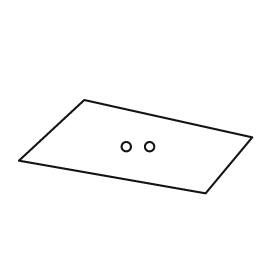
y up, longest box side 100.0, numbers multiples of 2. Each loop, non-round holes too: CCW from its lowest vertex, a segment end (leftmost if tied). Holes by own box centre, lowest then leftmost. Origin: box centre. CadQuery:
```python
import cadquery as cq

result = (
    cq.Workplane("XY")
    .moveTo(30.0, -20.0)
    .lineTo(50.0, 4.0)
    .lineTo(-22.0, 20.0)
    .lineTo(-50.0, -6.0)
    .close()
    .moveTo(-4.0, 0.0)
    .circle(2.0)
    .moveTo(6.0, 0.0)
    .circle(2.0)
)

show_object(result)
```